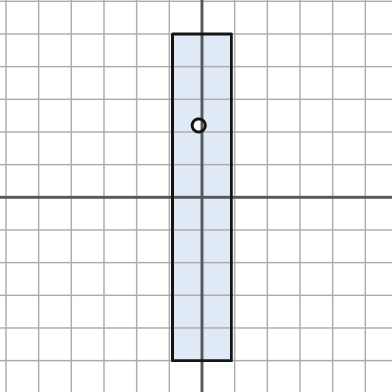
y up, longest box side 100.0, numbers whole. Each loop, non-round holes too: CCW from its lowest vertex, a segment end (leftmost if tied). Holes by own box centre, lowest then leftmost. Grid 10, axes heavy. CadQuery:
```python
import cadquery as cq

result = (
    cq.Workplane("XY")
    .moveTo(-9.0, -50.0)
    .lineTo(9.0, -50.0)
    .lineTo(9.0, 50.0)
    .lineTo(-9.0, 50.0)
    .close()
    .moveTo(-1.0, 22.0)
    .circle(2.0)
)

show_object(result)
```